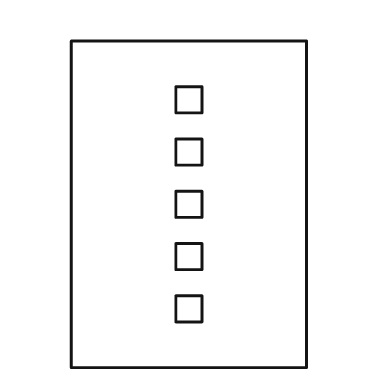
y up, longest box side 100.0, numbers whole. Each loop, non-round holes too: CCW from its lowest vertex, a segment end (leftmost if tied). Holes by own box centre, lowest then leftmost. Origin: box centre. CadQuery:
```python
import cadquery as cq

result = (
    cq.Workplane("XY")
    .moveTo(-36.0, -50.0)
    .lineTo(36.0, -50.0)
    .lineTo(36.0, 50.0)
    .lineTo(-36.0, 50.0)
    .close()
    .moveTo(-4.0, -36.0)
    .lineTo(4.0, -36.0)
    .lineTo(4.0, -28.0)
    .lineTo(-4.0, -28.0)
    .close()
    .moveTo(-4.0, -20.0)
    .lineTo(4.0, -20.0)
    .lineTo(4.0, -12.0)
    .lineTo(-4.0, -12.0)
    .close()
    .moveTo(-4.0, -4.0)
    .lineTo(4.0, -4.0)
    .lineTo(4.0, 4.0)
    .lineTo(-4.0, 4.0)
    .close()
    .moveTo(-4.0, 12.0)
    .lineTo(4.0, 12.0)
    .lineTo(4.0, 20.0)
    .lineTo(-4.0, 20.0)
    .close()
    .moveTo(-4.0, 28.0)
    .lineTo(4.0, 28.0)
    .lineTo(4.0, 36.0)
    .lineTo(-4.0, 36.0)
    .close()
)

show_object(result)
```